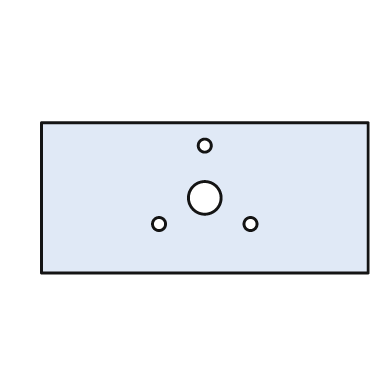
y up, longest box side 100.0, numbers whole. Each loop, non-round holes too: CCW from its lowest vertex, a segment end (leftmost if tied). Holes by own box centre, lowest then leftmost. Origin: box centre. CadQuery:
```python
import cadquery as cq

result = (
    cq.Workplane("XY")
    .moveTo(-50.0, -23.0)
    .lineTo(50.0, -23.0)
    .lineTo(50.0, 23.0)
    .lineTo(-50.0, 23.0)
    .close()
    .moveTo(-14.0, -8.0)
    .circle(2.0)
    .moveTo(14.0, -8.0)
    .circle(2.0)
    .moveTo(0.0, 0.0)
    .circle(5.0)
    .moveTo(0.0, 16.0)
    .circle(2.0)
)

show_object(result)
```